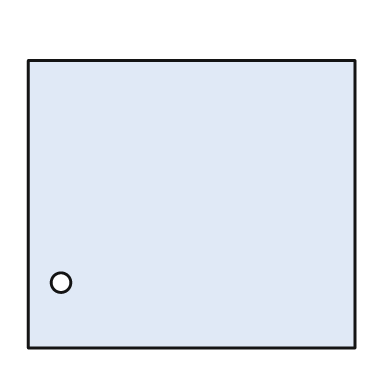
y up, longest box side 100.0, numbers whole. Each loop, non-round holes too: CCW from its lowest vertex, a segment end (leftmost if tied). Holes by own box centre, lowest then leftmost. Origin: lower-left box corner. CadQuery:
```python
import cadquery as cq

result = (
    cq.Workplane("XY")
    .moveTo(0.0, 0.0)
    .lineTo(100.0, 0.0)
    .lineTo(100.0, 88.0)
    .lineTo(0.0, 88.0)
    .close()
    .moveTo(10.0, 20.0)
    .circle(3.0)
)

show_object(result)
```